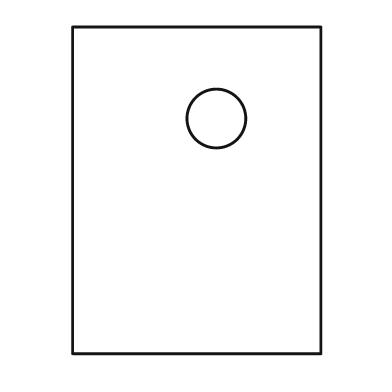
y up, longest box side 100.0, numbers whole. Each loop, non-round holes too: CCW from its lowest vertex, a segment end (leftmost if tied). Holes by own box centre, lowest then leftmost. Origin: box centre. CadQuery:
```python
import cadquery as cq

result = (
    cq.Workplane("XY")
    .moveTo(-38.0, -50.0)
    .lineTo(38.0, -50.0)
    .lineTo(38.0, 50.0)
    .lineTo(-38.0, 50.0)
    .close()
    .moveTo(6.0, 22.0)
    .circle(9.0)
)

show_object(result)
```